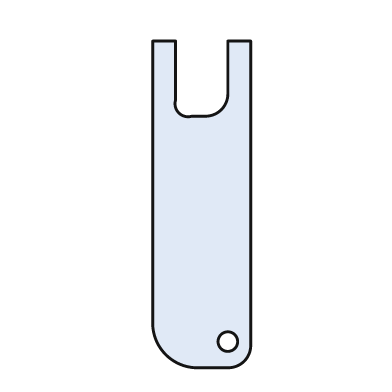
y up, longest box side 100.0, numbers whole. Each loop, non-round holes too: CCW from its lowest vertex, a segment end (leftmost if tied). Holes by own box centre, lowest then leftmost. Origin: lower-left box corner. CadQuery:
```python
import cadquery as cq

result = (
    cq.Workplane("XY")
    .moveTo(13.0, 0.0)
    .lineTo(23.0, 0.0)
    .threePointArc((28.0, 2.0), (30.0, 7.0))
    .lineTo(30.0, 100.0)
    .lineTo(23.0, 100.0)
    .lineTo(23.0, 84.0)
    .threePointArc((21.0, 79.0), (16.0, 77.0))
    .lineTo(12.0, 77.0)
    .threePointArc((8.0, 78.0), (7.0, 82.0))
    .lineTo(7.0, 100.0)
    .lineTo(0.0, 100.0)
    .lineTo(0.0, 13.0)
    .threePointArc((4.0, 4.0), (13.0, 0.0))
    .close()
    .moveTo(23.0, 8.0)
    .circle(3.0)
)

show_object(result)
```